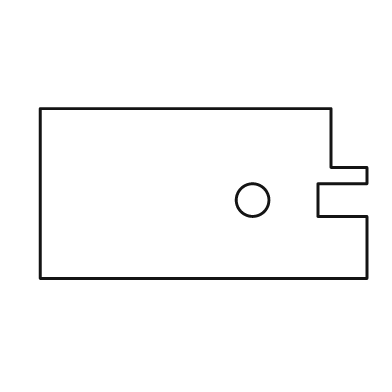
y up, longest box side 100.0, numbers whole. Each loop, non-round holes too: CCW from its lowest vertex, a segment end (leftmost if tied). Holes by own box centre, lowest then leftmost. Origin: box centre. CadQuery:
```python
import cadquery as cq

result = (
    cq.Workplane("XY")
    .moveTo(-50.0, -26.0)
    .lineTo(50.0, -26.0)
    .lineTo(50.0, -7.0)
    .lineTo(35.0, -7.0)
    .lineTo(35.0, 3.0)
    .lineTo(50.0, 3.0)
    .lineTo(50.0, 8.0)
    .lineTo(39.0, 8.0)
    .lineTo(39.0, 26.0)
    .lineTo(-50.0, 26.0)
    .close()
    .moveTo(15.0, -2.0)
    .circle(5.0)
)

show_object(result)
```